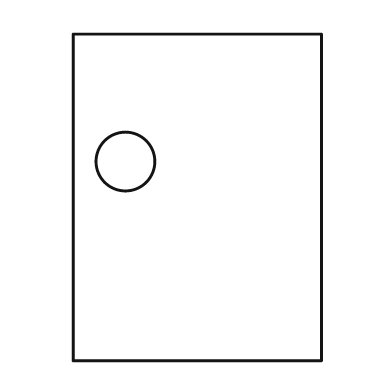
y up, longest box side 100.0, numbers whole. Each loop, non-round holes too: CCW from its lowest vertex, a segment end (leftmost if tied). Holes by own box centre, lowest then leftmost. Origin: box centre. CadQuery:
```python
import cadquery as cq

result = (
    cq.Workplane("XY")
    .moveTo(-38.0, -50.0)
    .lineTo(38.0, -50.0)
    .lineTo(38.0, 50.0)
    .lineTo(-38.0, 50.0)
    .close()
    .moveTo(-22.0, 11.0)
    .circle(9.0)
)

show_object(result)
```